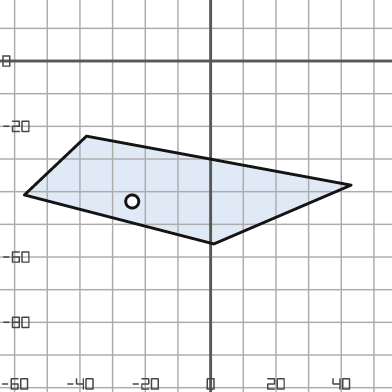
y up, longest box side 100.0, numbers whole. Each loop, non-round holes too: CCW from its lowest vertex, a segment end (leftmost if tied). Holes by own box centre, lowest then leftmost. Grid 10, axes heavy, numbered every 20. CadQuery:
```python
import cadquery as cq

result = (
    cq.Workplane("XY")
    .moveTo(1.0, -56.0)
    .lineTo(43.0, -38.0)
    .lineTo(-38.0, -23.0)
    .lineTo(-57.0, -41.0)
    .close()
    .moveTo(-24.0, -43.0)
    .circle(2.0)
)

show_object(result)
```